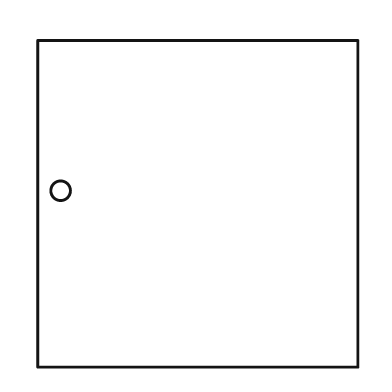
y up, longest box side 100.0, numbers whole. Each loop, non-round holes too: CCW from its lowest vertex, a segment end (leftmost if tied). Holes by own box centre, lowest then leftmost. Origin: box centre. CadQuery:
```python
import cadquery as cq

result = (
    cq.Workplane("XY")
    .moveTo(-49.0, -50.0)
    .lineTo(49.0, -50.0)
    .lineTo(49.0, 50.0)
    .lineTo(-49.0, 50.0)
    .close()
    .moveTo(-42.0, 4.0)
    .circle(3.0)
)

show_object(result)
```